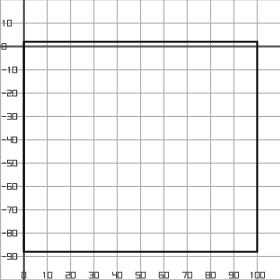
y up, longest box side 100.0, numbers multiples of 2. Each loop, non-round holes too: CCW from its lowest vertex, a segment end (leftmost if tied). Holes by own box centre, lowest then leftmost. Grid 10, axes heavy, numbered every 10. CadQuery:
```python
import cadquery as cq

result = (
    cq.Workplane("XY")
    .moveTo(0.0, -88.0)
    .lineTo(100.0, -88.0)
    .lineTo(100.0, 2.0)
    .lineTo(0.0, 2.0)
    .close()
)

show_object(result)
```